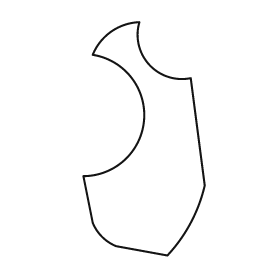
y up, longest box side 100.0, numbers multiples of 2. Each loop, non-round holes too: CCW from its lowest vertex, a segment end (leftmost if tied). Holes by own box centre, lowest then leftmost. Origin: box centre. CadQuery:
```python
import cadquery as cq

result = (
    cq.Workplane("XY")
    .moveTo(10.0, -50.0)
    .threePointArc((20.0, -36.0), (26.0, -20.0))
    .lineTo(20.0, 26.0)
    .threePointArc((2.0, 32.0), (-2.0, 50.0))
    .threePointArc((-14.0, 46.0), (-22.0, 36.0))
    .threePointArc((0.0, 8.0), (-26.0, -16.0))
    .lineTo(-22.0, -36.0)
    .threePointArc((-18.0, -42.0), (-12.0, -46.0))
    .close()
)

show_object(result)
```